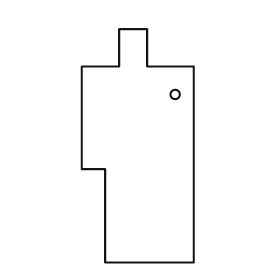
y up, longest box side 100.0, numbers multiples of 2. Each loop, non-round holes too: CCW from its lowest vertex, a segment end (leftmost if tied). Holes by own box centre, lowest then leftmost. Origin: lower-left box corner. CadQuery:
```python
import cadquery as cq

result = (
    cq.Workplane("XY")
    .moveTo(10.0, 0.0)
    .lineTo(48.0, 0.0)
    .lineTo(48.0, 84.0)
    .lineTo(28.0, 84.0)
    .lineTo(28.0, 100.0)
    .lineTo(16.0, 100.0)
    .lineTo(16.0, 84.0)
    .lineTo(0.0, 84.0)
    .lineTo(0.0, 40.0)
    .lineTo(10.0, 40.0)
    .close()
    .moveTo(40.0, 72.0)
    .circle(2.0)
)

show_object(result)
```